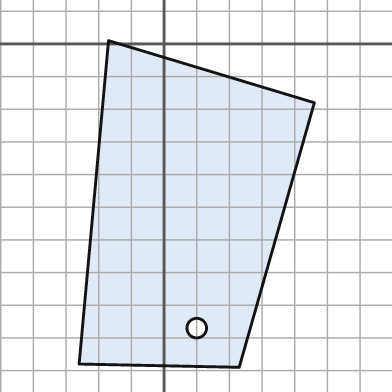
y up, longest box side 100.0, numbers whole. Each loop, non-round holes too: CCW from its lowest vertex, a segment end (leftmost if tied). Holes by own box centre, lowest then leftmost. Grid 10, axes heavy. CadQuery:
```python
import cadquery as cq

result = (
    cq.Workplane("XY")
    .moveTo(23.0, -99.0)
    .lineTo(46.0, -18.0)
    .lineTo(-17.0, 1.0)
    .lineTo(-26.0, -98.0)
    .close()
    .moveTo(10.0, -87.0)
    .circle(3.0)
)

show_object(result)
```